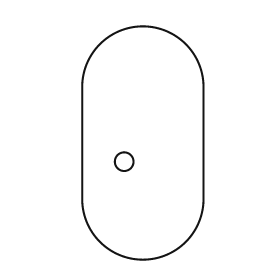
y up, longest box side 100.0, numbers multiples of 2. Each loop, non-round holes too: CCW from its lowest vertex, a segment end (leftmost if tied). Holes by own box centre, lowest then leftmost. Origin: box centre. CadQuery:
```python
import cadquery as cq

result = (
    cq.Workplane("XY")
    .moveTo(-26.0, -24.0)
    .threePointArc((0.0, -50.0), (26.0, -24.0))
    .lineTo(26.0, 24.0)
    .threePointArc((0.0, 50.0), (-26.0, 24.0))
    .close()
    .moveTo(-8.0, -8.0)
    .circle(4.0)
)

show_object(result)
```